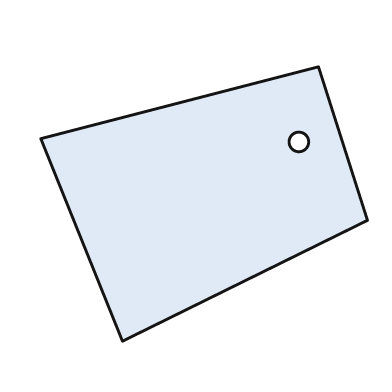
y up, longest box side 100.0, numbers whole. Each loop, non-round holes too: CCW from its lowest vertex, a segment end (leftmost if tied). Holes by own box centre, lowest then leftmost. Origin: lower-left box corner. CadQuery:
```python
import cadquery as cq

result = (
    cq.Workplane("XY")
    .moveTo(25.0, 0.0)
    .lineTo(100.0, 37.0)
    .lineTo(85.0, 84.0)
    .lineTo(0.0, 62.0)
    .close()
    .moveTo(79.0, 61.0)
    .circle(3.0)
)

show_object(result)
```